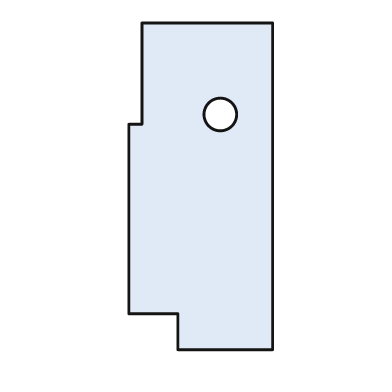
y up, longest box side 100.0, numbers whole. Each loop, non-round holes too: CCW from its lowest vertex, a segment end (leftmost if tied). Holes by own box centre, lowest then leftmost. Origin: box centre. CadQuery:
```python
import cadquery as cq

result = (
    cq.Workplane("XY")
    .moveTo(-7.0, -50.0)
    .lineTo(22.0, -50.0)
    .lineTo(22.0, 50.0)
    .lineTo(-18.0, 50.0)
    .lineTo(-18.0, 19.0)
    .lineTo(-22.0, 19.0)
    .lineTo(-22.0, -39.0)
    .lineTo(-7.0, -39.0)
    .close()
    .moveTo(6.0, 22.0)
    .circle(5.0)
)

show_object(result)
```